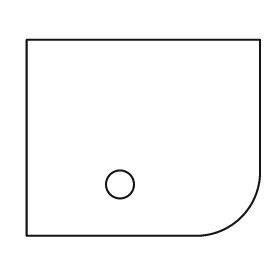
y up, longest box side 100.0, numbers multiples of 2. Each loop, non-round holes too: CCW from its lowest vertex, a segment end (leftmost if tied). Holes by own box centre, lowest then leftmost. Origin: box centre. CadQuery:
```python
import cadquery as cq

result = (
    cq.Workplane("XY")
    .moveTo(-50.0, -42.0)
    .lineTo(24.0, -42.0)
    .threePointArc((42.0, -34.0), (50.0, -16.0))
    .lineTo(50.0, 42.0)
    .lineTo(-50.0, 42.0)
    .close()
    .moveTo(-10.0, -20.0)
    .circle(6.0)
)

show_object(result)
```